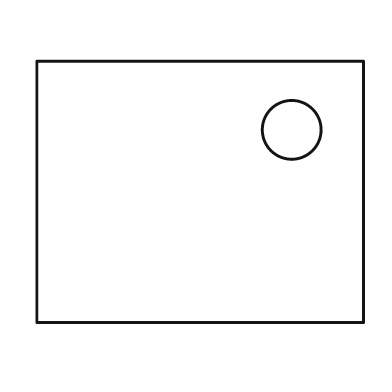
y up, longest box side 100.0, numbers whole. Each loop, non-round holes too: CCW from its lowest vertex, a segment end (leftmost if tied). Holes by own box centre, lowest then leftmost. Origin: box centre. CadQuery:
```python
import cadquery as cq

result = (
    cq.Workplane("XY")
    .moveTo(-50.0, -40.0)
    .lineTo(50.0, -40.0)
    .lineTo(50.0, 40.0)
    .lineTo(-50.0, 40.0)
    .close()
    .moveTo(28.0, 19.0)
    .circle(9.0)
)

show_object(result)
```